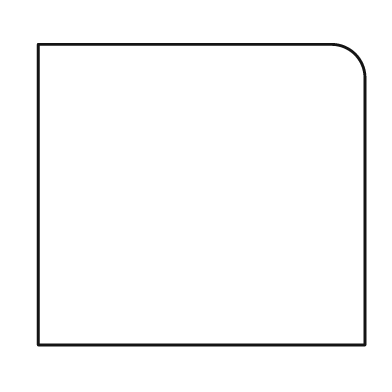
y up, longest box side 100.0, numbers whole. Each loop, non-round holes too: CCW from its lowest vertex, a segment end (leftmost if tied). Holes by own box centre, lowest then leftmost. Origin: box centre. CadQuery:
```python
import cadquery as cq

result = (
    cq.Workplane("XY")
    .moveTo(-50.0, -46.0)
    .lineTo(50.0, -46.0)
    .lineTo(50.0, 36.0)
    .threePointArc((47.0, 43.0), (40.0, 46.0))
    .lineTo(-50.0, 46.0)
    .close()
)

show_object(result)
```